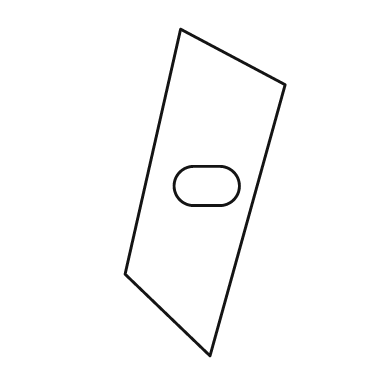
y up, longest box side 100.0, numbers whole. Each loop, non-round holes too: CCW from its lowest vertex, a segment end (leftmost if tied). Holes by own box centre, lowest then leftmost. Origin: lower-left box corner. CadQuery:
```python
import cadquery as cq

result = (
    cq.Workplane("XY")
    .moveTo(26.0, 0.0)
    .lineTo(49.0, 83.0)
    .lineTo(17.0, 100.0)
    .lineTo(0.0, 25.0)
    .close()
    .moveTo(21.0, 46.0)
    .lineTo(29.0, 46.0)
    .threePointArc((35.0, 52.0), (29.0, 58.0))
    .lineTo(21.0, 58.0)
    .threePointArc((15.0, 52.0), (21.0, 46.0))
    .close()
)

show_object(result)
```